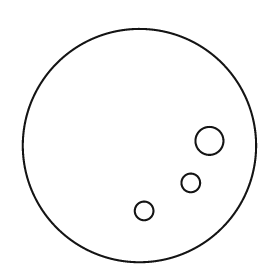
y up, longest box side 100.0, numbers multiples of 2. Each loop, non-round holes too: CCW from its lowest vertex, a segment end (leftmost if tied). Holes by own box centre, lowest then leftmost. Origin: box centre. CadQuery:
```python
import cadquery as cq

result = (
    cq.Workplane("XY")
    .moveTo(0.0, 0.0)
    .circle(50.0)
    .moveTo(2.0, -28.0)
    .circle(4.0)
    .moveTo(22.0, -16.0)
    .circle(4.0)
    .moveTo(30.0, 2.0)
    .circle(6.0)
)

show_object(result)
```